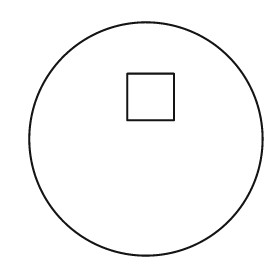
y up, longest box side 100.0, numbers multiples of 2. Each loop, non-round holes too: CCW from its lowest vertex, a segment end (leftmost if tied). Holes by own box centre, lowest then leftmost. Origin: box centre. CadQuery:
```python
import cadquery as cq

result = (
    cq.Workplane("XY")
    .moveTo(0.0, 0.0)
    .circle(50.0)
    .moveTo(-8.0, 8.0)
    .lineTo(12.0, 8.0)
    .lineTo(12.0, 28.0)
    .lineTo(-8.0, 28.0)
    .close()
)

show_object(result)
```